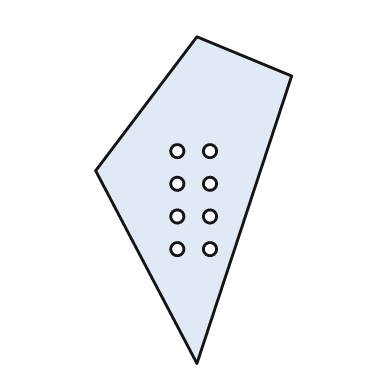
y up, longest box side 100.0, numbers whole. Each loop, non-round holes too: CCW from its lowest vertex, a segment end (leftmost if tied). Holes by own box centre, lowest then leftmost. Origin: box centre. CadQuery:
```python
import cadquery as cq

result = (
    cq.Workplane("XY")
    .moveTo(1.0, -50.0)
    .lineTo(30.0, 38.0)
    .lineTo(1.0, 50.0)
    .lineTo(-30.0, 9.0)
    .close()
    .moveTo(-5.0, -15.0)
    .circle(2.0)
    .moveTo(5.0, -15.0)
    .circle(2.0)
    .moveTo(-5.0, -5.0)
    .circle(2.0)
    .moveTo(5.0, -5.0)
    .circle(2.0)
    .moveTo(-5.0, 5.0)
    .circle(2.0)
    .moveTo(5.0, 5.0)
    .circle(2.0)
    .moveTo(-5.0, 15.0)
    .circle(2.0)
    .moveTo(5.0, 15.0)
    .circle(2.0)
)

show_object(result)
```